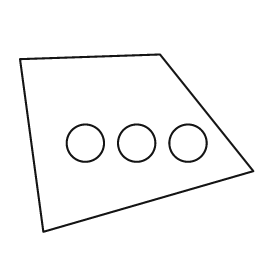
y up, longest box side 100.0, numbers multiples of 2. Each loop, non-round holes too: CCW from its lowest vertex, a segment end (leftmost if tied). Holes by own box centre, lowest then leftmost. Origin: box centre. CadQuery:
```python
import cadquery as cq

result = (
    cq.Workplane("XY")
    .moveTo(-40.0, -38.0)
    .lineTo(50.0, -12.0)
    .lineTo(10.0, 38.0)
    .lineTo(-50.0, 36.0)
    .close()
    .moveTo(-22.0, 0.0)
    .circle(8.0)
    .moveTo(0.0, 0.0)
    .circle(8.0)
    .moveTo(22.0, 0.0)
    .circle(8.0)
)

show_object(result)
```